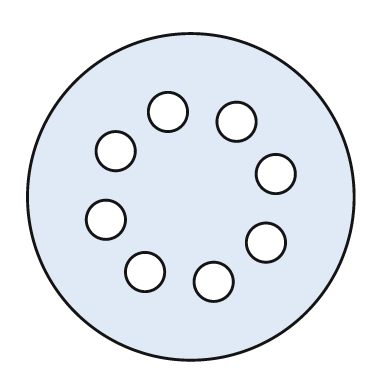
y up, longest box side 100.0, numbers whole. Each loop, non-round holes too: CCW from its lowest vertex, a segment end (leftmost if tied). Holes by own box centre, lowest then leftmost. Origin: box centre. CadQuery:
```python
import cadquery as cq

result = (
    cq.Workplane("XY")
    .moveTo(0.0, 0.0)
    .circle(50.0)
    .moveTo(7.0, -26.0)
    .circle(6.0)
    .moveTo(-14.0, -23.0)
    .circle(6.0)
    .moveTo(23.0, -14.0)
    .circle(6.0)
    .moveTo(-26.0, -7.0)
    .circle(6.0)
    .moveTo(26.0, 7.0)
    .circle(6.0)
    .moveTo(-23.0, 14.0)
    .circle(6.0)
    .moveTo(14.0, 23.0)
    .circle(6.0)
    .moveTo(-7.0, 26.0)
    .circle(6.0)
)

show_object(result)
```